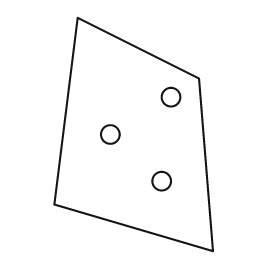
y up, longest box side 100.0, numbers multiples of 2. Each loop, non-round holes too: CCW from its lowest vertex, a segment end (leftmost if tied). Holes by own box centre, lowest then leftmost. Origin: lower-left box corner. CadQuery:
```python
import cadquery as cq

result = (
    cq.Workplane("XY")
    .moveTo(68.0, 0.0)
    .lineTo(62.0, 74.0)
    .lineTo(10.0, 100.0)
    .lineTo(0.0, 20.0)
    .close()
    .moveTo(46.0, 30.0)
    .circle(4.0)
    .moveTo(24.0, 50.0)
    .circle(4.0)
    .moveTo(50.0, 66.0)
    .circle(4.0)
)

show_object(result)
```